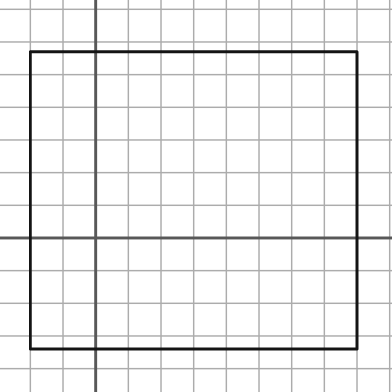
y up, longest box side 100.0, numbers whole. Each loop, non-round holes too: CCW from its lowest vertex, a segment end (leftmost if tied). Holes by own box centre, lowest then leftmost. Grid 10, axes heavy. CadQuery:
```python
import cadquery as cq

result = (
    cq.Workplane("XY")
    .moveTo(-20.0, -34.0)
    .lineTo(80.0, -34.0)
    .lineTo(80.0, 57.0)
    .lineTo(-20.0, 57.0)
    .close()
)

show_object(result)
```